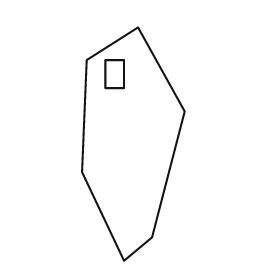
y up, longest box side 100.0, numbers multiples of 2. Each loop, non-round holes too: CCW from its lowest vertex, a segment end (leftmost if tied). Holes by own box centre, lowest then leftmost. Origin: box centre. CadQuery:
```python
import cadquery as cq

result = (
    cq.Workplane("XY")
    .moveTo(-4.0, -50.0)
    .lineTo(8.0, -40.0)
    .lineTo(22.0, 14.0)
    .lineTo(2.0, 50.0)
    .lineTo(-20.0, 36.0)
    .lineTo(-22.0, -12.0)
    .close()
    .moveTo(-12.0, 24.0)
    .lineTo(-4.0, 24.0)
    .lineTo(-4.0, 36.0)
    .lineTo(-12.0, 36.0)
    .close()
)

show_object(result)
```